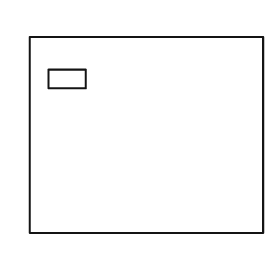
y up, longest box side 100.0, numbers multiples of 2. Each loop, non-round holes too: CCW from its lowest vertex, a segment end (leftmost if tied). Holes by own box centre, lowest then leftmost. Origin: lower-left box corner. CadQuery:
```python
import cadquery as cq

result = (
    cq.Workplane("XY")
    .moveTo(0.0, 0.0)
    .lineTo(100.0, 0.0)
    .lineTo(100.0, 84.0)
    .lineTo(0.0, 84.0)
    .close()
    .moveTo(8.0, 62.0)
    .lineTo(24.0, 62.0)
    .lineTo(24.0, 70.0)
    .lineTo(8.0, 70.0)
    .close()
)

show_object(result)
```